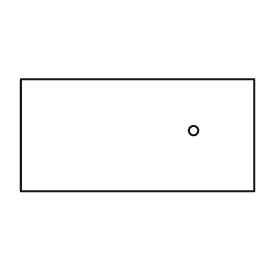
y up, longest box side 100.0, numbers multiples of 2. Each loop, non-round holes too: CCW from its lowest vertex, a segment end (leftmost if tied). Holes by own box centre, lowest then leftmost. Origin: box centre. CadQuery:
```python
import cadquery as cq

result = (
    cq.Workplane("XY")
    .moveTo(-50.0, -24.0)
    .lineTo(50.0, -24.0)
    .lineTo(50.0, 24.0)
    .lineTo(-50.0, 24.0)
    .close()
    .moveTo(24.0, 2.0)
    .circle(2.0)
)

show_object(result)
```